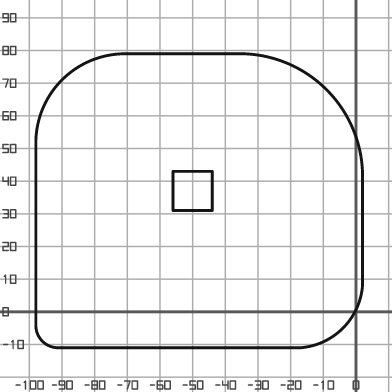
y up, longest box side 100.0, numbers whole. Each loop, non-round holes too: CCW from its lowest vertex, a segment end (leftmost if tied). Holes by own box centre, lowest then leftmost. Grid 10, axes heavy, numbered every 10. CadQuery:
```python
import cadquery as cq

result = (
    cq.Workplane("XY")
    .moveTo(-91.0, -11.0)
    .lineTo(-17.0, -11.0)
    .threePointArc((-4.0, -5.0), (2.0, 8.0))
    .lineTo(2.0, 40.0)
    .threePointArc((-9.0, 68.0), (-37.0, 79.0))
    .lineTo(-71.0, 79.0)
    .threePointArc((-90.0, 71.0), (-98.0, 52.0))
    .lineTo(-98.0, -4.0)
    .threePointArc((-96.0, -9.0), (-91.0, -11.0))
    .close()
    .moveTo(-56.0, 31.0)
    .lineTo(-44.0, 31.0)
    .lineTo(-44.0, 43.0)
    .lineTo(-56.0, 43.0)
    .close()
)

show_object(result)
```